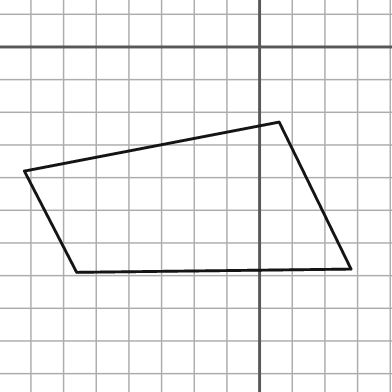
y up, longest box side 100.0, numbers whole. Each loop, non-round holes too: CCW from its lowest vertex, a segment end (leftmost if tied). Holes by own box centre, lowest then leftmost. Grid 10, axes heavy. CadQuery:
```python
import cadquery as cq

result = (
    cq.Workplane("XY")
    .moveTo(-56.0, -69.0)
    .lineTo(28.0, -68.0)
    .lineTo(6.0, -23.0)
    .lineTo(-72.0, -38.0)
    .close()
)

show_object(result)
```